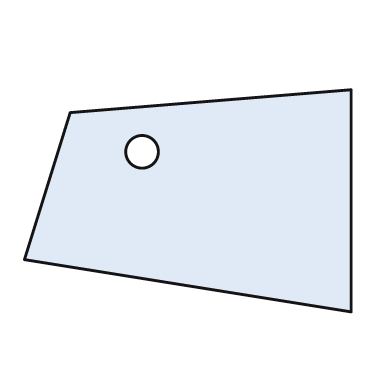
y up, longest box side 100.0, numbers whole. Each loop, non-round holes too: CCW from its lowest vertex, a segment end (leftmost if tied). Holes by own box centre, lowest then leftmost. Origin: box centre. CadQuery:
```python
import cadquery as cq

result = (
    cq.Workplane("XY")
    .moveTo(50.0, -34.0)
    .lineTo(50.0, 34.0)
    .lineTo(-36.0, 27.0)
    .lineTo(-50.0, -18.0)
    .close()
    .moveTo(-14.0, 15.0)
    .circle(5.0)
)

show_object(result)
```